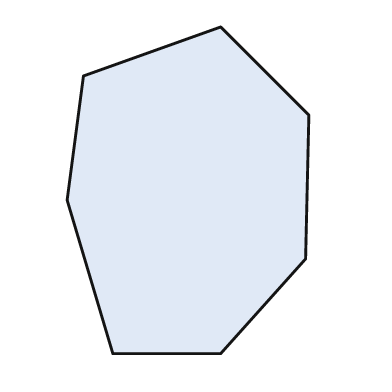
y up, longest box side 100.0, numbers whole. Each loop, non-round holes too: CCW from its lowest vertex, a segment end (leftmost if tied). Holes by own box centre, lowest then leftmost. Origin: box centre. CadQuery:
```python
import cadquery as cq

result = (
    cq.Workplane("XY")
    .moveTo(-23.0, -50.0)
    .lineTo(10.0, -50.0)
    .lineTo(36.0, -21.0)
    .lineTo(37.0, 23.0)
    .lineTo(10.0, 50.0)
    .lineTo(-32.0, 35.0)
    .lineTo(-37.0, -3.0)
    .close()
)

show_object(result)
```